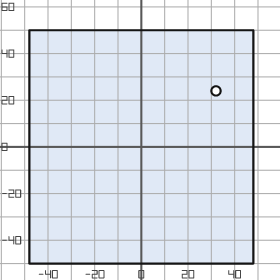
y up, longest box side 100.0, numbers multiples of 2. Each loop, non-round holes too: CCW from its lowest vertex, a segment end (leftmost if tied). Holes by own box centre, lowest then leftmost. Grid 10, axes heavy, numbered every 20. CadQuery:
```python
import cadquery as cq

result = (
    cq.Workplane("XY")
    .moveTo(-48.0, -50.0)
    .lineTo(48.0, -50.0)
    .lineTo(48.0, 50.0)
    .lineTo(-48.0, 50.0)
    .close()
    .moveTo(32.0, 24.0)
    .circle(2.0)
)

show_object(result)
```